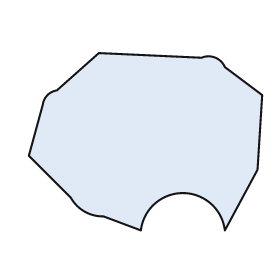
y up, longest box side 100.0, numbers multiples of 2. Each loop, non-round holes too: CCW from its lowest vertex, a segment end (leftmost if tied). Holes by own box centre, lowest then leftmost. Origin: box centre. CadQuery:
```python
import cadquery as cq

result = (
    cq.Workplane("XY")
    .moveTo(-2.0, -38.0)
    .threePointArc((16.0, -22.0), (34.0, -38.0))
    .lineTo(48.0, -12.0)
    .lineTo(50.0, 20.0)
    .lineTo(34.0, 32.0)
    .threePointArc((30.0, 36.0), (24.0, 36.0))
    .lineTo(-20.0, 38.0)
    .lineTo(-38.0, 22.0)
    .threePointArc((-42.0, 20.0), (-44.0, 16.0))
    .lineTo(-50.0, -6.0)
    .lineTo(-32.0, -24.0)
    .threePointArc((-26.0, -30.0), (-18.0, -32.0))
    .close()
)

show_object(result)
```